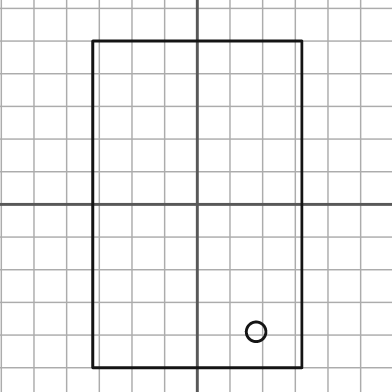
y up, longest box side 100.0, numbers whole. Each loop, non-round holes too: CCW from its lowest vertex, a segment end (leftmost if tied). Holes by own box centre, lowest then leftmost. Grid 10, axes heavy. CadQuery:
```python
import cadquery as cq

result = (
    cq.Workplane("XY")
    .moveTo(-32.0, -50.0)
    .lineTo(32.0, -50.0)
    .lineTo(32.0, 50.0)
    .lineTo(-32.0, 50.0)
    .close()
    .moveTo(18.0, -39.0)
    .circle(3.0)
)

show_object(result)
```